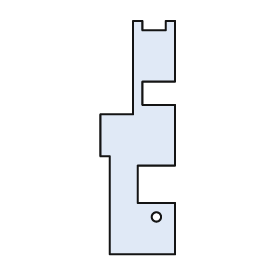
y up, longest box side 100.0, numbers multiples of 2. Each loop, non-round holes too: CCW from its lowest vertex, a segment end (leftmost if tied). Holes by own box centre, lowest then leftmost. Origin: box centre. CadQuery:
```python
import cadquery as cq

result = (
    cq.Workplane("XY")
    .moveTo(-12.0, -50.0)
    .lineTo(16.0, -50.0)
    .lineTo(16.0, -28.0)
    .lineTo(0.0, -28.0)
    .lineTo(0.0, -12.0)
    .lineTo(16.0, -12.0)
    .lineTo(16.0, 14.0)
    .lineTo(2.0, 14.0)
    .lineTo(2.0, 24.0)
    .lineTo(16.0, 24.0)
    .lineTo(16.0, 50.0)
    .lineTo(12.0, 50.0)
    .lineTo(12.0, 46.0)
    .lineTo(2.0, 46.0)
    .lineTo(2.0, 50.0)
    .lineTo(-2.0, 50.0)
    .lineTo(-2.0, 10.0)
    .lineTo(-16.0, 10.0)
    .lineTo(-16.0, -8.0)
    .lineTo(-12.0, -8.0)
    .close()
    .moveTo(8.0, -34.0)
    .circle(2.0)
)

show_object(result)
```